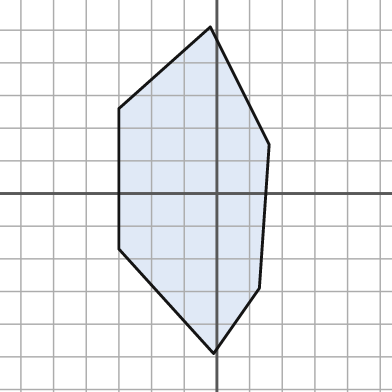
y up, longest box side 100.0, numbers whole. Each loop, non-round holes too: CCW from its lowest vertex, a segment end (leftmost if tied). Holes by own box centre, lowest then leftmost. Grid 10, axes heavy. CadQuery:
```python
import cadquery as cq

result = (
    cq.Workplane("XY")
    .moveTo(-1.0, -49.0)
    .lineTo(13.0, -29.0)
    .lineTo(16.0, 15.0)
    .lineTo(-2.0, 51.0)
    .lineTo(-30.0, 26.0)
    .lineTo(-30.0, -17.0)
    .close()
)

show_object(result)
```